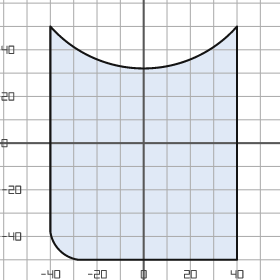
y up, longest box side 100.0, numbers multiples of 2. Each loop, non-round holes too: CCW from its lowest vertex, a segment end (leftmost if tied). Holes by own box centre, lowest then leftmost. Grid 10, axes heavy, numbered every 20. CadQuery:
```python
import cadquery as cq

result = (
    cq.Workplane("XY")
    .moveTo(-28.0, -50.0)
    .lineTo(40.0, -50.0)
    .lineTo(40.0, 50.0)
    .threePointArc((0.0, 32.0), (-40.0, 50.0))
    .lineTo(-40.0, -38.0)
    .threePointArc((-36.0, -46.0), (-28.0, -50.0))
    .close()
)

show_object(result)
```